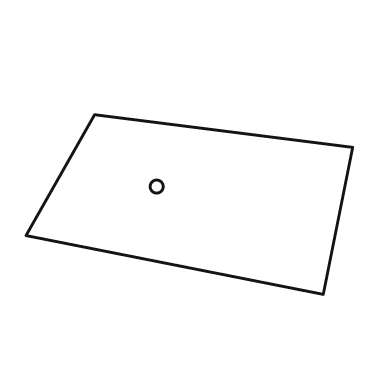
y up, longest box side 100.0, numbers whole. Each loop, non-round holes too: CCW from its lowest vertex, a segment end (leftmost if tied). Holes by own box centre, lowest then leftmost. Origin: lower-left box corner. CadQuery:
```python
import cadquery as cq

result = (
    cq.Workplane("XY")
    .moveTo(91.0, 0.0)
    .lineTo(100.0, 45.0)
    .lineTo(21.0, 55.0)
    .lineTo(0.0, 18.0)
    .close()
    .moveTo(40.0, 33.0)
    .circle(2.0)
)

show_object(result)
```